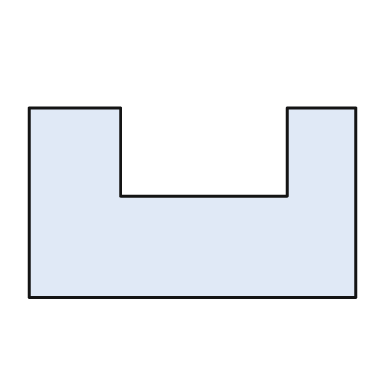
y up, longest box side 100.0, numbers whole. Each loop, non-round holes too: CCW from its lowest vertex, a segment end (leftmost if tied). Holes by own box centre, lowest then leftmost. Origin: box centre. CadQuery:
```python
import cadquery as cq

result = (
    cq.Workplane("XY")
    .moveTo(-50.0, -29.0)
    .lineTo(50.0, -29.0)
    .lineTo(50.0, 29.0)
    .lineTo(29.0, 29.0)
    .lineTo(29.0, 2.0)
    .lineTo(-22.0, 2.0)
    .lineTo(-22.0, 29.0)
    .lineTo(-50.0, 29.0)
    .close()
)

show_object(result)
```